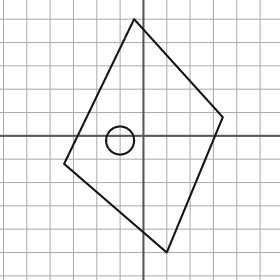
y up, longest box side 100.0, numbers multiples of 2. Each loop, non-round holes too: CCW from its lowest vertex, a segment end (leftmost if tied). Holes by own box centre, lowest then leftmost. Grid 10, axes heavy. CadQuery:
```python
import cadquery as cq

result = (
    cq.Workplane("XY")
    .moveTo(10.0, -50.0)
    .lineTo(34.0, 8.0)
    .lineTo(-4.0, 50.0)
    .lineTo(-34.0, -12.0)
    .close()
    .moveTo(-10.0, -2.0)
    .circle(6.0)
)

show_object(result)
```